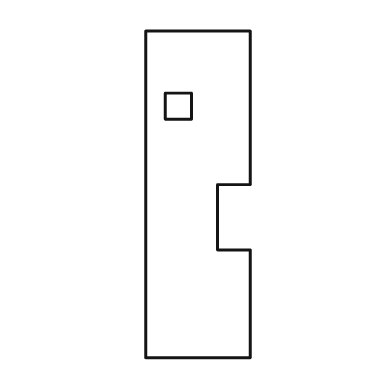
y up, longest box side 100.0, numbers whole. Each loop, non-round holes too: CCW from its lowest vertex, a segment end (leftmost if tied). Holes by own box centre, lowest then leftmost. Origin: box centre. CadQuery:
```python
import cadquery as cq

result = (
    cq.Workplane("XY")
    .moveTo(-16.0, -50.0)
    .lineTo(16.0, -50.0)
    .lineTo(16.0, -17.0)
    .lineTo(6.0, -17.0)
    .lineTo(6.0, 3.0)
    .lineTo(16.0, 3.0)
    .lineTo(16.0, 50.0)
    .lineTo(-16.0, 50.0)
    .close()
    .moveTo(-10.0, 23.0)
    .lineTo(-2.0, 23.0)
    .lineTo(-2.0, 31.0)
    .lineTo(-10.0, 31.0)
    .close()
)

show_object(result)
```